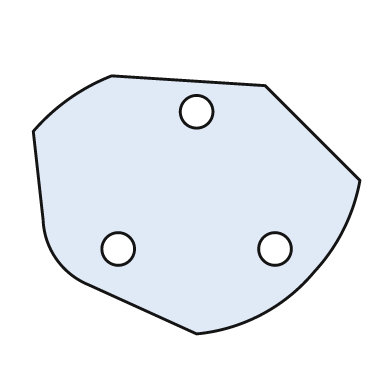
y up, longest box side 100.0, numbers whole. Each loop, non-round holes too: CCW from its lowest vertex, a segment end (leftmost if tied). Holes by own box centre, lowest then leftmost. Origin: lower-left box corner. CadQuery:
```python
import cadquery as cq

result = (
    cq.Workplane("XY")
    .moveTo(50.0, 0.0)
    .threePointArc((70.0, 6.0), (86.0, 19.0))
    .threePointArc((95.0, 32.0), (100.0, 47.0))
    .lineTo(71.0, 76.0)
    .lineTo(24.0, 79.0)
    .threePointArc((11.0, 72.0), (0.0, 62.0))
    .lineTo(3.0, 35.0)
    .threePointArc((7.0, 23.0), (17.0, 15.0))
    .close()
    .moveTo(26.0, 26.0)
    .circle(5.0)
    .moveTo(74.0, 26.0)
    .circle(5.0)
    .moveTo(50.0, 68.0)
    .circle(5.0)
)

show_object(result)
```